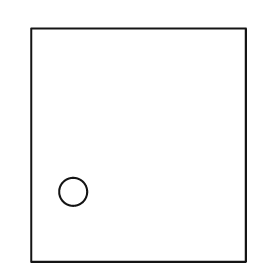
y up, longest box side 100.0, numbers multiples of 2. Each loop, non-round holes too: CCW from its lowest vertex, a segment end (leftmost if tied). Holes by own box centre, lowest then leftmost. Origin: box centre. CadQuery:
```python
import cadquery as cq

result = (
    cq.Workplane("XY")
    .moveTo(-46.0, -50.0)
    .lineTo(46.0, -50.0)
    .lineTo(46.0, 50.0)
    .lineTo(-46.0, 50.0)
    .close()
    .moveTo(-28.0, -20.0)
    .circle(6.0)
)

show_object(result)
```